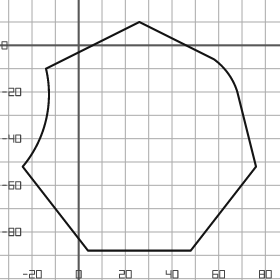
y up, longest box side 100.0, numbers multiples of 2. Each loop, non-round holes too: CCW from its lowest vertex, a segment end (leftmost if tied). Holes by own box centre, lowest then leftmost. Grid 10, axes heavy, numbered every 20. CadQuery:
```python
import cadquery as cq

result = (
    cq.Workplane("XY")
    .moveTo(4.0, -88.0)
    .lineTo(48.0, -88.0)
    .lineTo(76.0, -52.0)
    .lineTo(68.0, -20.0)
    .threePointArc((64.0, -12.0), (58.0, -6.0))
    .lineTo(26.0, 10.0)
    .lineTo(-14.0, -10.0)
    .threePointArc((-14.0, -32.0), (-24.0, -52.0))
    .close()
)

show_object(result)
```